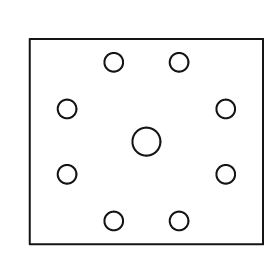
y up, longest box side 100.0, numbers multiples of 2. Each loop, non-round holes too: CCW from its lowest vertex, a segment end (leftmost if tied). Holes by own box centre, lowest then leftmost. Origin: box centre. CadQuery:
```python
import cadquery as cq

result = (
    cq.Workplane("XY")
    .moveTo(-50.0, -44.0)
    .lineTo(50.0, -44.0)
    .lineTo(50.0, 44.0)
    .lineTo(-50.0, 44.0)
    .close()
    .moveTo(-14.0, -34.0)
    .circle(4.0)
    .moveTo(14.0, -34.0)
    .circle(4.0)
    .moveTo(-34.0, -14.0)
    .circle(4.0)
    .moveTo(34.0, -14.0)
    .circle(4.0)
    .moveTo(0.0, 0.0)
    .circle(6.0)
    .moveTo(-34.0, 14.0)
    .circle(4.0)
    .moveTo(34.0, 14.0)
    .circle(4.0)
    .moveTo(-14.0, 34.0)
    .circle(4.0)
    .moveTo(14.0, 34.0)
    .circle(4.0)
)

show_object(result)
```